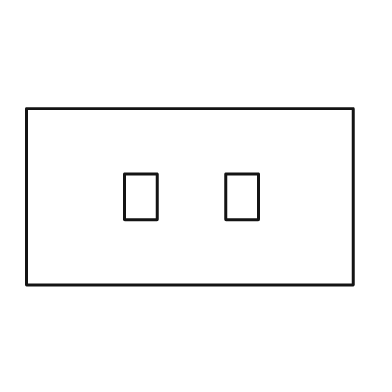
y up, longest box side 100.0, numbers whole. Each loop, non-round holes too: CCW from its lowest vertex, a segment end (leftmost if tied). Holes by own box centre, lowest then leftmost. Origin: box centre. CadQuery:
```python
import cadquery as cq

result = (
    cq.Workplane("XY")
    .moveTo(-50.0, -27.0)
    .lineTo(50.0, -27.0)
    .lineTo(50.0, 27.0)
    .lineTo(-50.0, 27.0)
    .close()
    .moveTo(-20.0, -7.0)
    .lineTo(-10.0, -7.0)
    .lineTo(-10.0, 7.0)
    .lineTo(-20.0, 7.0)
    .close()
    .moveTo(11.0, -7.0)
    .lineTo(21.0, -7.0)
    .lineTo(21.0, 7.0)
    .lineTo(11.0, 7.0)
    .close()
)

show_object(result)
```